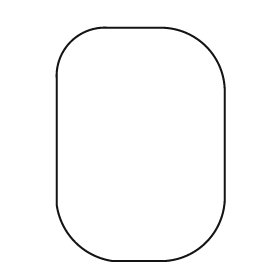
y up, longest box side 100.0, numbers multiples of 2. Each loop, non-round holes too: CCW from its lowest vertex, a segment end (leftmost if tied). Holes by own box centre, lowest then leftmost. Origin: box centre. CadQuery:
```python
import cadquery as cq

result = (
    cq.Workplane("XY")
    .moveTo(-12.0, -50.0)
    .lineTo(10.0, -50.0)
    .threePointArc((28.0, -42.0), (36.0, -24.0))
    .lineTo(36.0, 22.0)
    .threePointArc((28.0, 42.0), (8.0, 50.0))
    .lineTo(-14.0, 50.0)
    .threePointArc((-30.0, 44.0), (-36.0, 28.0))
    .lineTo(-36.0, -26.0)
    .threePointArc((-28.0, -42.0), (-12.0, -50.0))
    .close()
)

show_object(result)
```